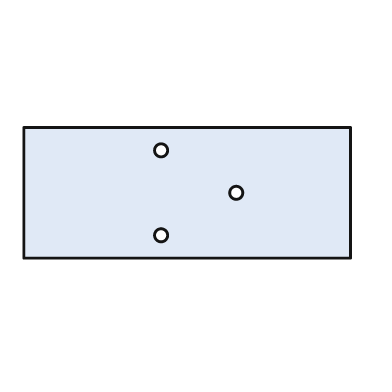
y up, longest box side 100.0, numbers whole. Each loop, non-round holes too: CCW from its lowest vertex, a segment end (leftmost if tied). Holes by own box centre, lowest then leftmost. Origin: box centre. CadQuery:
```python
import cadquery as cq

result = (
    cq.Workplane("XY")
    .moveTo(-50.0, -20.0)
    .lineTo(50.0, -20.0)
    .lineTo(50.0, 20.0)
    .lineTo(-50.0, 20.0)
    .close()
    .moveTo(-8.0, -13.0)
    .circle(2.0)
    .moveTo(15.0, 0.0)
    .circle(2.0)
    .moveTo(-8.0, 13.0)
    .circle(2.0)
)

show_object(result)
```